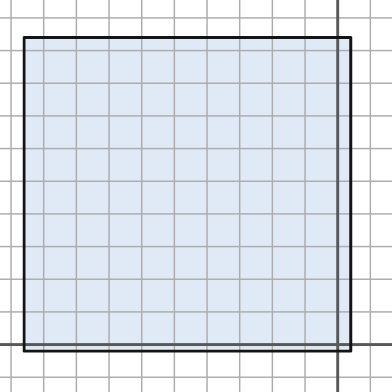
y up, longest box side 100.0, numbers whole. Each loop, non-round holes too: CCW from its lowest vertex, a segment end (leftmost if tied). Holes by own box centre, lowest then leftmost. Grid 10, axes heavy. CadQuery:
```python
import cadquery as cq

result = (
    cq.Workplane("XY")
    .moveTo(-96.0, -2.0)
    .lineTo(4.0, -2.0)
    .lineTo(4.0, 94.0)
    .lineTo(-96.0, 94.0)
    .close()
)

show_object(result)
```